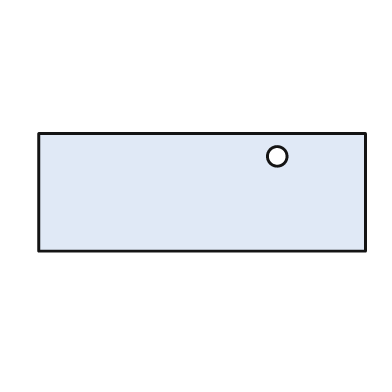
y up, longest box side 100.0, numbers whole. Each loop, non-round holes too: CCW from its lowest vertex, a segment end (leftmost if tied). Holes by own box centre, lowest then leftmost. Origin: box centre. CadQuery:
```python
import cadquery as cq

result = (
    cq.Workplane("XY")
    .moveTo(-50.0, -18.0)
    .lineTo(50.0, -18.0)
    .lineTo(50.0, 18.0)
    .lineTo(-50.0, 18.0)
    .close()
    .moveTo(23.0, 11.0)
    .circle(3.0)
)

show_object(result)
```